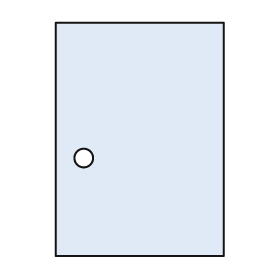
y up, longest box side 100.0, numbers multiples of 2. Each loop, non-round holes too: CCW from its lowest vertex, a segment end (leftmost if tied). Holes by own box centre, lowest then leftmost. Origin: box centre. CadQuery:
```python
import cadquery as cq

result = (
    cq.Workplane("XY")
    .moveTo(-36.0, -50.0)
    .lineTo(36.0, -50.0)
    .lineTo(36.0, 50.0)
    .lineTo(-36.0, 50.0)
    .close()
    .moveTo(-24.0, -8.0)
    .circle(4.0)
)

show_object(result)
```